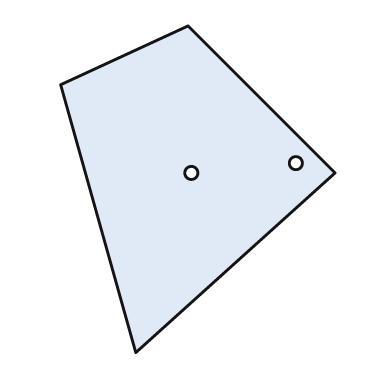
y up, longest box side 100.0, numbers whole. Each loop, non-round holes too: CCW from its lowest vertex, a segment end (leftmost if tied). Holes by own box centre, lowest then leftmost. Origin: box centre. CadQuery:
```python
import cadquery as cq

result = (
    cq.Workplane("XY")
    .moveTo(-19.0, -50.0)
    .lineTo(42.0, 5.0)
    .lineTo(-3.0, 50.0)
    .lineTo(-42.0, 32.0)
    .close()
    .moveTo(-2.0, 5.0)
    .circle(2.0)
    .moveTo(30.0, 8.0)
    .circle(2.0)
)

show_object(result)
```